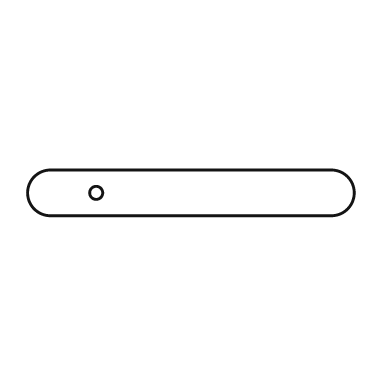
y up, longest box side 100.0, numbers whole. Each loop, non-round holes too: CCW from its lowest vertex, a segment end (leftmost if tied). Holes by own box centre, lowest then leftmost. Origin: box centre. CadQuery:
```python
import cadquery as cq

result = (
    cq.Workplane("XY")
    .moveTo(-43.0, -7.0)
    .lineTo(43.0, -7.0)
    .threePointArc((50.0, 0.0), (43.0, 7.0))
    .lineTo(-43.0, 7.0)
    .threePointArc((-50.0, 0.0), (-43.0, -7.0))
    .close()
    .moveTo(-29.0, 0.0)
    .circle(2.0)
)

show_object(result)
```